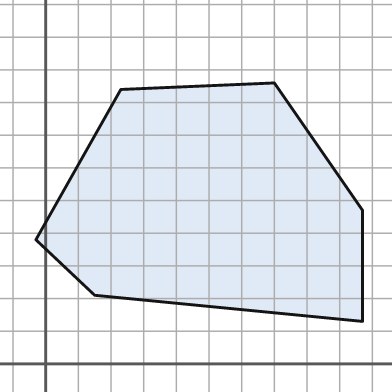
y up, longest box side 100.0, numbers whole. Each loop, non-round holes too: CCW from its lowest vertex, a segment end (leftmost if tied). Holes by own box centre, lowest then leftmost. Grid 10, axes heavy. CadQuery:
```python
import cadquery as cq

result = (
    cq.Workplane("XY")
    .moveTo(97.0, 13.0)
    .lineTo(97.0, 47.0)
    .lineTo(70.0, 86.0)
    .lineTo(23.0, 84.0)
    .lineTo(-3.0, 38.0)
    .lineTo(15.0, 21.0)
    .close()
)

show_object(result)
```